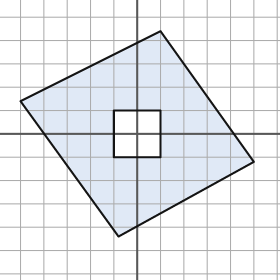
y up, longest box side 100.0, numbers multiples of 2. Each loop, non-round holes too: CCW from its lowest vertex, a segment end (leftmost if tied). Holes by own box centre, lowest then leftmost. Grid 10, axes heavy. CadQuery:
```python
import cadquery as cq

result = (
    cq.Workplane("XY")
    .moveTo(-8.0, -44.0)
    .lineTo(50.0, -12.0)
    .lineTo(10.0, 44.0)
    .lineTo(-50.0, 14.0)
    .close()
    .moveTo(-10.0, -10.0)
    .lineTo(10.0, -10.0)
    .lineTo(10.0, 10.0)
    .lineTo(-10.0, 10.0)
    .close()
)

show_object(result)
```